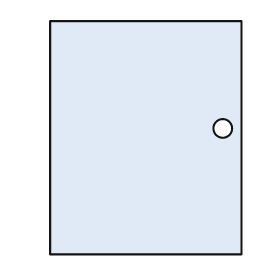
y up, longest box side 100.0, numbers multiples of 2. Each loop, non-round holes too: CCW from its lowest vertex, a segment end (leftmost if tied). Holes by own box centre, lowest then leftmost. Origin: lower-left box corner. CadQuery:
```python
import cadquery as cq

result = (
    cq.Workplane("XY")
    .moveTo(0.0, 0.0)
    .lineTo(82.0, 0.0)
    .lineTo(82.0, 100.0)
    .lineTo(0.0, 100.0)
    .close()
    .moveTo(74.0, 54.0)
    .circle(4.0)
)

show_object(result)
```